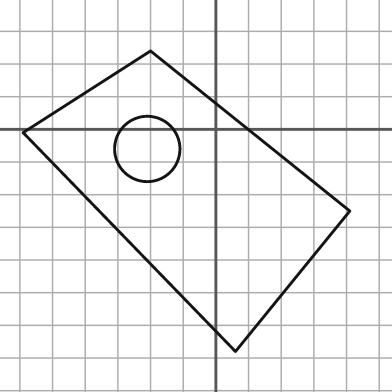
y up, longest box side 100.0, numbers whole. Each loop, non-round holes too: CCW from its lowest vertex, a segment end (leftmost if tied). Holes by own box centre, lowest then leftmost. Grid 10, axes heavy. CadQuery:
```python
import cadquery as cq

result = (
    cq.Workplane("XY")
    .moveTo(6.0, -68.0)
    .lineTo(41.0, -25.0)
    .lineTo(-20.0, 24.0)
    .lineTo(-59.0, -1.0)
    .close()
    .moveTo(-21.0, -6.0)
    .circle(10.0)
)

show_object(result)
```